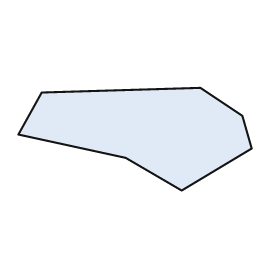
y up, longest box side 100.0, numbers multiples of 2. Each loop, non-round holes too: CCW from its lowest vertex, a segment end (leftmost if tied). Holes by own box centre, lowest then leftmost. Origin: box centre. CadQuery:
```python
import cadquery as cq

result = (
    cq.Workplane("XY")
    .moveTo(20.0, -22.0)
    .lineTo(50.0, -4.0)
    .lineTo(46.0, 10.0)
    .lineTo(28.0, 22.0)
    .lineTo(-40.0, 20.0)
    .lineTo(-50.0, 2.0)
    .lineTo(-4.0, -8.0)
    .close()
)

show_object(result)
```